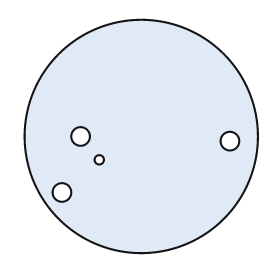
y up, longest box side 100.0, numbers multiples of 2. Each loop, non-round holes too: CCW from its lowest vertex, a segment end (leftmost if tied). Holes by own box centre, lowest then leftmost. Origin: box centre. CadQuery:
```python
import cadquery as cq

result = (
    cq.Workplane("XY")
    .moveTo(0.0, 0.0)
    .circle(50.0)
    .moveTo(-34.0, -24.0)
    .circle(4.0)
    .moveTo(-18.0, -10.0)
    .circle(2.0)
    .moveTo(38.0, -2.0)
    .circle(4.0)
    .moveTo(-26.0, 0.0)
    .circle(4.0)
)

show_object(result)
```